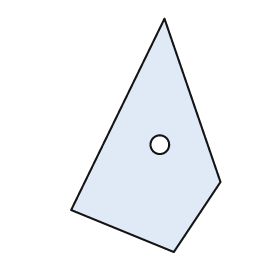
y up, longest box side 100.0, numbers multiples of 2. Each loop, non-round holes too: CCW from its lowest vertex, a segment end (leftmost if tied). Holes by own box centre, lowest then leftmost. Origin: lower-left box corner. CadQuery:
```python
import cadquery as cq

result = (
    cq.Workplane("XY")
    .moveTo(44.0, 0.0)
    .lineTo(64.0, 30.0)
    .lineTo(40.0, 100.0)
    .lineTo(0.0, 18.0)
    .close()
    .moveTo(38.0, 46.0)
    .circle(4.0)
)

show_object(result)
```